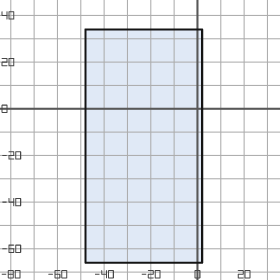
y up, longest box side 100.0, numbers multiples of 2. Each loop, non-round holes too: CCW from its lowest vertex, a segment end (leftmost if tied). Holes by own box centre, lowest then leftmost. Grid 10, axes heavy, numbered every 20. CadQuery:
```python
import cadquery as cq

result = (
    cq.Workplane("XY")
    .moveTo(-48.0, -66.0)
    .lineTo(2.0, -66.0)
    .lineTo(2.0, 34.0)
    .lineTo(-48.0, 34.0)
    .close()
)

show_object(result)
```